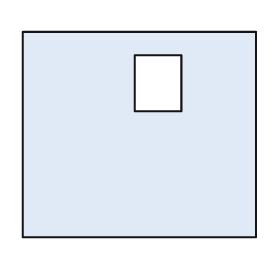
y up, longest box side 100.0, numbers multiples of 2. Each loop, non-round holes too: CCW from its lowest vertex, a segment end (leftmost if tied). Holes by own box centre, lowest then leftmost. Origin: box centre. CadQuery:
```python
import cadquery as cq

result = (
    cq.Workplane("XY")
    .moveTo(-50.0, -44.0)
    .lineTo(50.0, -44.0)
    .lineTo(50.0, 44.0)
    .lineTo(-50.0, 44.0)
    .close()
    .moveTo(-2.0, 10.0)
    .lineTo(18.0, 10.0)
    .lineTo(18.0, 34.0)
    .lineTo(-2.0, 34.0)
    .close()
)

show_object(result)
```